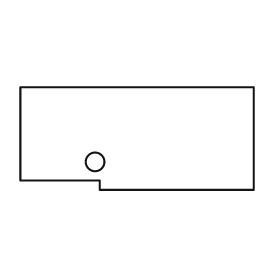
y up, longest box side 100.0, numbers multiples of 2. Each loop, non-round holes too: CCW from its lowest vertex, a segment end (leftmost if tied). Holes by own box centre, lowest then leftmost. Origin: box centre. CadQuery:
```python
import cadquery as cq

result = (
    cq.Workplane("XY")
    .moveTo(-16.0, -22.0)
    .lineTo(50.0, -22.0)
    .lineTo(50.0, 22.0)
    .lineTo(-50.0, 22.0)
    .lineTo(-50.0, -18.0)
    .lineTo(-16.0, -18.0)
    .close()
    .moveTo(-18.0, -10.0)
    .circle(4.0)
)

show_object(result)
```